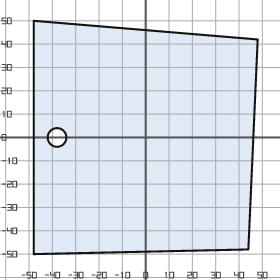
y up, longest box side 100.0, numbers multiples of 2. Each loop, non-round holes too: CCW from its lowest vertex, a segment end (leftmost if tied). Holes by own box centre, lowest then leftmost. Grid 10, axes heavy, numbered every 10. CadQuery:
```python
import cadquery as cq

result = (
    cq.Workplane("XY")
    .moveTo(-48.0, -50.0)
    .lineTo(44.0, -48.0)
    .lineTo(48.0, 42.0)
    .lineTo(-48.0, 50.0)
    .close()
    .moveTo(-38.0, 0.0)
    .circle(4.0)
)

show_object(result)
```